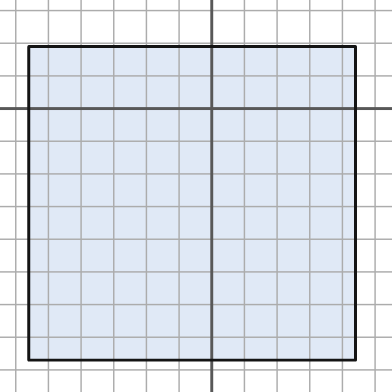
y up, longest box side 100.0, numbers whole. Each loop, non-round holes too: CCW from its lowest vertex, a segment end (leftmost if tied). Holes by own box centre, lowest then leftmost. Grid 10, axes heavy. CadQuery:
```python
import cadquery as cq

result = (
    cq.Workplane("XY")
    .moveTo(-56.0, -77.0)
    .lineTo(44.0, -77.0)
    .lineTo(44.0, 19.0)
    .lineTo(-56.0, 19.0)
    .close()
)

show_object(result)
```